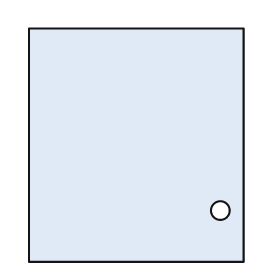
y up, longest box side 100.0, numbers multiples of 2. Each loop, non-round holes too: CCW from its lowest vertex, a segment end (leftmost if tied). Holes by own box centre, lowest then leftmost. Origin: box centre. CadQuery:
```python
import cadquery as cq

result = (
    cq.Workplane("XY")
    .moveTo(-46.0, -50.0)
    .lineTo(46.0, -50.0)
    .lineTo(46.0, 50.0)
    .lineTo(-46.0, 50.0)
    .close()
    .moveTo(36.0, -28.0)
    .circle(4.0)
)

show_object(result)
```